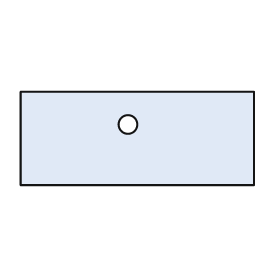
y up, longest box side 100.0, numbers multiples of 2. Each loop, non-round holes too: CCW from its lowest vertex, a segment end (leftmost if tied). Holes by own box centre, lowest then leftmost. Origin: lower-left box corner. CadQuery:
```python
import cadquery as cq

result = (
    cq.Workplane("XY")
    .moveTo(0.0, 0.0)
    .lineTo(100.0, 0.0)
    .lineTo(100.0, 40.0)
    .lineTo(0.0, 40.0)
    .close()
    .moveTo(46.0, 26.0)
    .circle(4.0)
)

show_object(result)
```